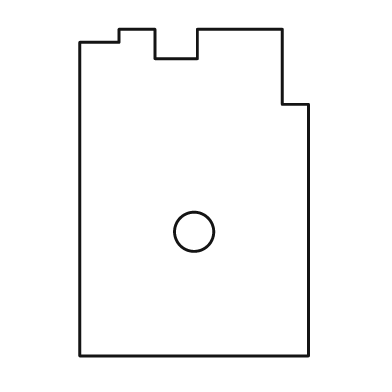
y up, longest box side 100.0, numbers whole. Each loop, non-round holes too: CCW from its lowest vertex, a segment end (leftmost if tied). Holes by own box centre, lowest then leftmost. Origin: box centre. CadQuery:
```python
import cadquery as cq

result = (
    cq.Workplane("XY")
    .moveTo(-35.0, -50.0)
    .lineTo(35.0, -50.0)
    .lineTo(35.0, 27.0)
    .lineTo(27.0, 27.0)
    .lineTo(27.0, 50.0)
    .lineTo(1.0, 50.0)
    .lineTo(1.0, 41.0)
    .lineTo(-12.0, 41.0)
    .lineTo(-12.0, 50.0)
    .lineTo(-23.0, 50.0)
    .lineTo(-23.0, 46.0)
    .lineTo(-35.0, 46.0)
    .close()
    .moveTo(0.0, -12.0)
    .circle(6.0)
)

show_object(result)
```